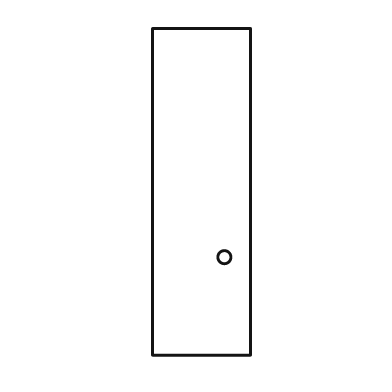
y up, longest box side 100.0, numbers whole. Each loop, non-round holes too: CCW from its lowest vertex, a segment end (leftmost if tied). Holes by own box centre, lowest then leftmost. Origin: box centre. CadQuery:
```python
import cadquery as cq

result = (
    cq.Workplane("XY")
    .moveTo(-15.0, -50.0)
    .lineTo(15.0, -50.0)
    .lineTo(15.0, 50.0)
    .lineTo(-15.0, 50.0)
    .close()
    .moveTo(7.0, -20.0)
    .circle(2.0)
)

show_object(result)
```